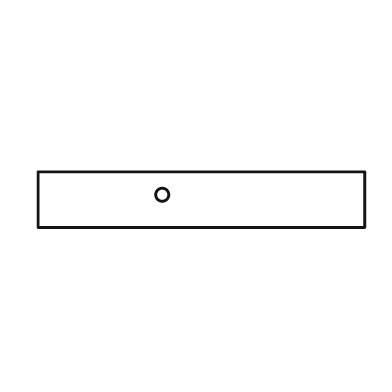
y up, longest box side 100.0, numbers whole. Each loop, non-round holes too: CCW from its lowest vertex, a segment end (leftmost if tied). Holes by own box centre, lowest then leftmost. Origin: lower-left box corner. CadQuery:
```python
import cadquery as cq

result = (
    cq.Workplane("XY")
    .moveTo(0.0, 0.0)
    .lineTo(100.0, 0.0)
    .lineTo(100.0, 17.0)
    .lineTo(0.0, 17.0)
    .close()
    .moveTo(38.0, 10.0)
    .circle(2.0)
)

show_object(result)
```